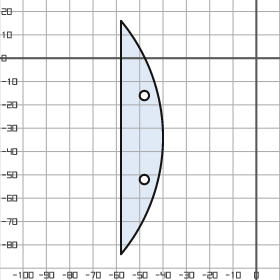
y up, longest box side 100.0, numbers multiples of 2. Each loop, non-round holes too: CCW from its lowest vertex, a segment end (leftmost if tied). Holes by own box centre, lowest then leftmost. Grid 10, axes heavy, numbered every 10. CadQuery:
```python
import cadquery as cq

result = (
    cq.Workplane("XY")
    .moveTo(-58.0, -84.0)
    .threePointArc((-40.0, -34.0), (-58.0, 16.0))
    .close()
    .moveTo(-48.0, -52.0)
    .circle(2.0)
    .moveTo(-48.0, -16.0)
    .circle(2.0)
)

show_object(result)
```